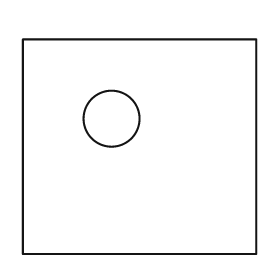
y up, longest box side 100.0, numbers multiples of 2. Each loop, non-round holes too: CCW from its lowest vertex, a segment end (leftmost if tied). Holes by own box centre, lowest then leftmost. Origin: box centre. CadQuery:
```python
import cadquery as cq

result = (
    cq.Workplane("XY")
    .moveTo(-50.0, -46.0)
    .lineTo(50.0, -46.0)
    .lineTo(50.0, 46.0)
    .lineTo(-50.0, 46.0)
    .close()
    .moveTo(-12.0, 12.0)
    .circle(12.0)
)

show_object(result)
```